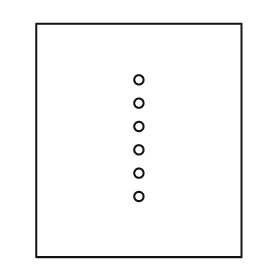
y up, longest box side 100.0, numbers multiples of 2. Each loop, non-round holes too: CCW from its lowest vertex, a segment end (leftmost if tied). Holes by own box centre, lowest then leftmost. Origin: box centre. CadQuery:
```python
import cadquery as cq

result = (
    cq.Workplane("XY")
    .moveTo(-44.0, -50.0)
    .lineTo(44.0, -50.0)
    .lineTo(44.0, 50.0)
    .lineTo(-44.0, 50.0)
    .close()
    .moveTo(0.0, -24.0)
    .circle(2.0)
    .moveTo(0.0, -14.0)
    .circle(2.0)
    .moveTo(0.0, -4.0)
    .circle(2.0)
    .moveTo(0.0, 6.0)
    .circle(2.0)
    .moveTo(0.0, 16.0)
    .circle(2.0)
    .moveTo(0.0, 26.0)
    .circle(2.0)
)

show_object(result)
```